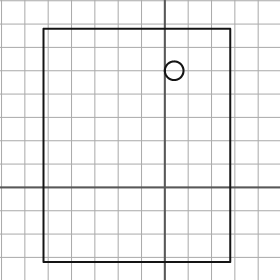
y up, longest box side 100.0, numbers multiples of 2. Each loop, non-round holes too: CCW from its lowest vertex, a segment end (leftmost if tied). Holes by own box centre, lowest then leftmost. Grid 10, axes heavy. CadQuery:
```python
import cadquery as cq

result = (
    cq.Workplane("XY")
    .moveTo(-52.0, -32.0)
    .lineTo(28.0, -32.0)
    .lineTo(28.0, 68.0)
    .lineTo(-52.0, 68.0)
    .close()
    .moveTo(4.0, 50.0)
    .circle(4.0)
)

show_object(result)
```